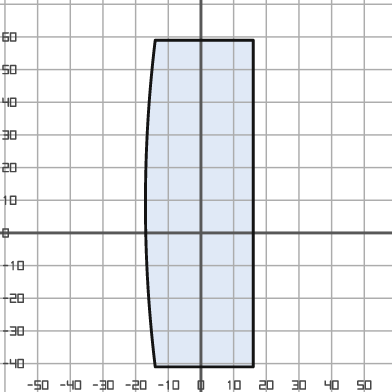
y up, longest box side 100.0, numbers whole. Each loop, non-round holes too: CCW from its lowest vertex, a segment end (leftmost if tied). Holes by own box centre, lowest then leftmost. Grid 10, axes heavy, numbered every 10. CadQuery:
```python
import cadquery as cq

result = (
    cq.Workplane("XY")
    .moveTo(-14.0, -41.0)
    .lineTo(16.0, -41.0)
    .lineTo(16.0, 59.0)
    .lineTo(-14.0, 59.0)
    .threePointArc((-17.0, 9.0), (-14.0, -41.0))
    .close()
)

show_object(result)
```